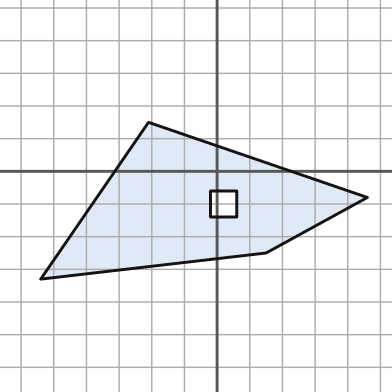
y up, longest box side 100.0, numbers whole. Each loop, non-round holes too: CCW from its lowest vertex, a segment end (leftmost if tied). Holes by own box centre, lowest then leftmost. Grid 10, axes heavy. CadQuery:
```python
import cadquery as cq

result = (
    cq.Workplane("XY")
    .moveTo(-54.0, -33.0)
    .lineTo(15.0, -25.0)
    .lineTo(46.0, -8.0)
    .lineTo(-21.0, 15.0)
    .close()
    .moveTo(-2.0, -14.0)
    .lineTo(6.0, -14.0)
    .lineTo(6.0, -6.0)
    .lineTo(-2.0, -6.0)
    .close()
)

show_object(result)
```